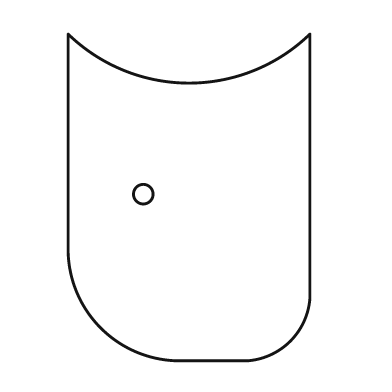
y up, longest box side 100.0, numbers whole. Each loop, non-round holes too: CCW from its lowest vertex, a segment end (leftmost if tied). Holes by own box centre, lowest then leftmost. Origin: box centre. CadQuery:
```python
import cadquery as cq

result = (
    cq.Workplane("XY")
    .moveTo(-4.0, -50.0)
    .lineTo(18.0, -50.0)
    .threePointArc((31.0, -44.0), (37.0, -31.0))
    .lineTo(37.0, 50.0)
    .threePointArc((0.0, 35.0), (-37.0, 50.0))
    .lineTo(-37.0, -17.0)
    .threePointArc((-27.0, -40.0), (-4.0, -50.0))
    .close()
    .moveTo(-14.0, 1.0)
    .circle(3.0)
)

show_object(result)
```